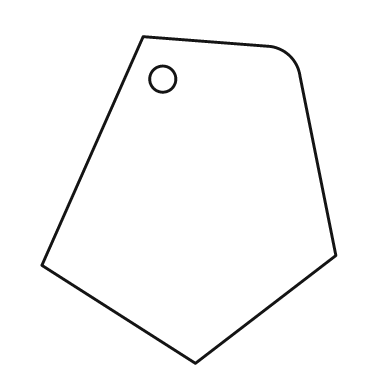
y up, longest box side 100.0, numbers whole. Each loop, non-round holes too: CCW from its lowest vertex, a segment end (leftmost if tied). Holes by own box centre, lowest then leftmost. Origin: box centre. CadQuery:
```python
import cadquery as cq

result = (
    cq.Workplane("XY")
    .moveTo(2.0, -50.0)
    .lineTo(45.0, -17.0)
    .lineTo(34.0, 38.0)
    .threePointArc((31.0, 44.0), (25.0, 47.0))
    .lineTo(-14.0, 50.0)
    .lineTo(-45.0, -20.0)
    .close()
    .moveTo(-8.0, 37.0)
    .circle(4.0)
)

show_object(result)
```